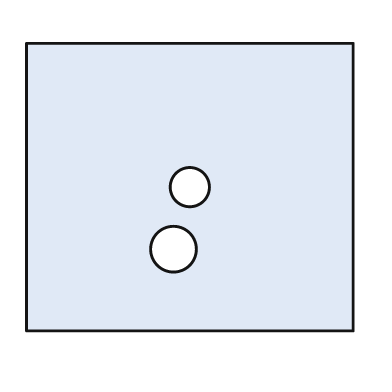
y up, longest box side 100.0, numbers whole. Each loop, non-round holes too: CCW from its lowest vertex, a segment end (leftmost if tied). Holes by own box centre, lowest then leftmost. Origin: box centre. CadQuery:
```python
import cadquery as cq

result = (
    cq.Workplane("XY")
    .moveTo(-50.0, -44.0)
    .lineTo(50.0, -44.0)
    .lineTo(50.0, 44.0)
    .lineTo(-50.0, 44.0)
    .close()
    .moveTo(-5.0, -19.0)
    .circle(7.0)
    .moveTo(0.0, 0.0)
    .circle(6.0)
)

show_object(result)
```